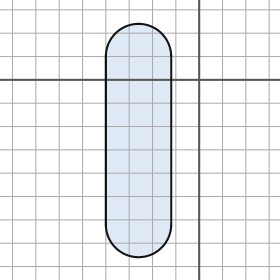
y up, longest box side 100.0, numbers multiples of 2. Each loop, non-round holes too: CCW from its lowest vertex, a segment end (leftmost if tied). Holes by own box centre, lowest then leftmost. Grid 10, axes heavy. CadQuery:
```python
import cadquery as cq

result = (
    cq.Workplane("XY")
    .moveTo(-40.0, -62.0)
    .threePointArc((-26.0, -76.0), (-12.0, -62.0))
    .lineTo(-12.0, 10.0)
    .threePointArc((-26.0, 24.0), (-40.0, 10.0))
    .close()
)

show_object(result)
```